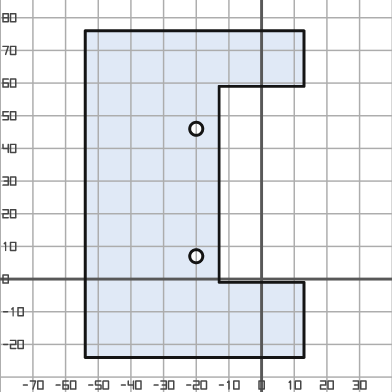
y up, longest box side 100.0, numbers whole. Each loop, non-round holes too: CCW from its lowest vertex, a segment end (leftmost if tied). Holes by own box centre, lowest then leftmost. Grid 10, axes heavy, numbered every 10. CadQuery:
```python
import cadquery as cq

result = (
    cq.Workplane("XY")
    .moveTo(-54.0, -24.0)
    .lineTo(13.0, -24.0)
    .lineTo(13.0, -1.0)
    .lineTo(-13.0, -1.0)
    .lineTo(-13.0, 59.0)
    .lineTo(13.0, 59.0)
    .lineTo(13.0, 76.0)
    .lineTo(-54.0, 76.0)
    .close()
    .moveTo(-20.0, 7.0)
    .circle(2.0)
    .moveTo(-20.0, 46.0)
    .circle(2.0)
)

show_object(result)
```